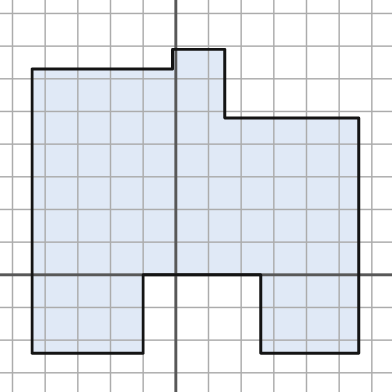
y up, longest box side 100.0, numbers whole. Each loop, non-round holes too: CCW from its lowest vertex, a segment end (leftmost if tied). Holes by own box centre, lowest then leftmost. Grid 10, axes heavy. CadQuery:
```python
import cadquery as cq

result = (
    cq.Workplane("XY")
    .moveTo(-44.0, -24.0)
    .lineTo(-10.0, -24.0)
    .lineTo(-10.0, 0.0)
    .lineTo(26.0, 0.0)
    .lineTo(26.0, -24.0)
    .lineTo(56.0, -24.0)
    .lineTo(56.0, 48.0)
    .lineTo(15.0, 48.0)
    .lineTo(15.0, 69.0)
    .lineTo(-1.0, 69.0)
    .lineTo(-1.0, 63.0)
    .lineTo(-44.0, 63.0)
    .close()
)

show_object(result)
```